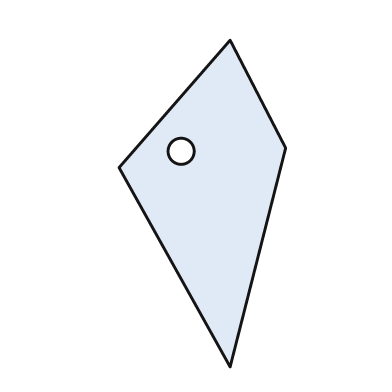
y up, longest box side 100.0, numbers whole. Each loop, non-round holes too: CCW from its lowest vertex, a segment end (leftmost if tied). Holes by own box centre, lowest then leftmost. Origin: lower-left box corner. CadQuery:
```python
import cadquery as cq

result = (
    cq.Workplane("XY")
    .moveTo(34.0, 0.0)
    .lineTo(51.0, 67.0)
    .lineTo(34.0, 100.0)
    .lineTo(0.0, 61.0)
    .close()
    .moveTo(19.0, 66.0)
    .circle(4.0)
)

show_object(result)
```